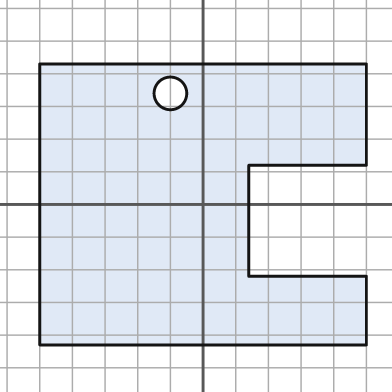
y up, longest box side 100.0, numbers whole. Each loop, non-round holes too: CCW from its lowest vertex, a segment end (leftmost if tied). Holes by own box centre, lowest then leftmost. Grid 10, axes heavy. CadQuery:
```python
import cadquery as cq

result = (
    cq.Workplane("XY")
    .moveTo(-50.0, -43.0)
    .lineTo(50.0, -43.0)
    .lineTo(50.0, -22.0)
    .lineTo(14.0, -22.0)
    .lineTo(14.0, 12.0)
    .lineTo(50.0, 12.0)
    .lineTo(50.0, 43.0)
    .lineTo(-50.0, 43.0)
    .close()
    .moveTo(-10.0, 34.0)
    .circle(5.0)
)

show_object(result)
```